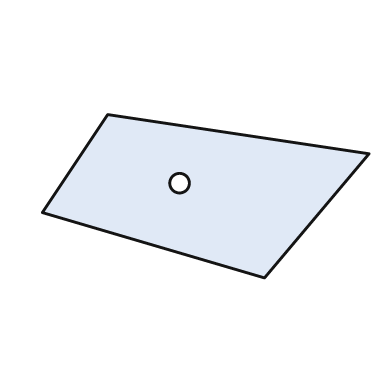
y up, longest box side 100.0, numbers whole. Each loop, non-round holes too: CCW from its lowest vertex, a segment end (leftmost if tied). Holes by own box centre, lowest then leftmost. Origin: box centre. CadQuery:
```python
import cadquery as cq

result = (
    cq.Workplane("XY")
    .moveTo(18.0, -25.0)
    .lineTo(50.0, 13.0)
    .lineTo(-30.0, 25.0)
    .lineTo(-50.0, -5.0)
    .close()
    .moveTo(-8.0, 4.0)
    .circle(3.0)
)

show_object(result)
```